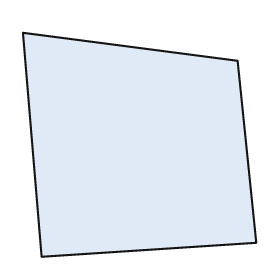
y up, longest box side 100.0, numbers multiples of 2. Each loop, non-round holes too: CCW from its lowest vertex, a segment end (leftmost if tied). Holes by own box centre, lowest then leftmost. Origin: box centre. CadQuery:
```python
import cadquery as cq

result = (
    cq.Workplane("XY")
    .moveTo(-42.0, -48.0)
    .lineTo(50.0, -42.0)
    .lineTo(42.0, 36.0)
    .lineTo(-50.0, 48.0)
    .close()
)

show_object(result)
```